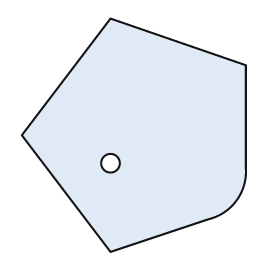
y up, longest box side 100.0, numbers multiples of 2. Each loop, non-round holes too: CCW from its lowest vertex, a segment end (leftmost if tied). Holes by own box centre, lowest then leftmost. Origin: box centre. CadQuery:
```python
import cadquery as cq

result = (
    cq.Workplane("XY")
    .moveTo(-10.0, -50.0)
    .lineTo(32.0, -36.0)
    .threePointArc((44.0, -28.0), (48.0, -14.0))
    .lineTo(48.0, 30.0)
    .lineTo(-10.0, 50.0)
    .lineTo(-48.0, 0.0)
    .close()
    .moveTo(-10.0, -12.0)
    .circle(4.0)
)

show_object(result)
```